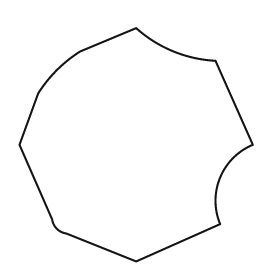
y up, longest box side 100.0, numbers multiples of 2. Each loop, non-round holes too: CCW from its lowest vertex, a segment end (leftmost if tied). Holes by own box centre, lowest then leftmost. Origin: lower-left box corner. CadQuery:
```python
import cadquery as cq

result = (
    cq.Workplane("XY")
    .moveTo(50.0, 0.0)
    .lineTo(86.0, 16.0)
    .threePointArc((86.0, 36.0), (100.0, 50.0))
    .lineTo(84.0, 86.0)
    .threePointArc((66.0, 90.0), (50.0, 100.0))
    .lineTo(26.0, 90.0)
    .threePointArc((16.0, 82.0), (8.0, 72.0))
    .lineTo(0.0, 50.0)
    .lineTo(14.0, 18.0)
    .threePointArc((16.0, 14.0), (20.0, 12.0))
    .close()
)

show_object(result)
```